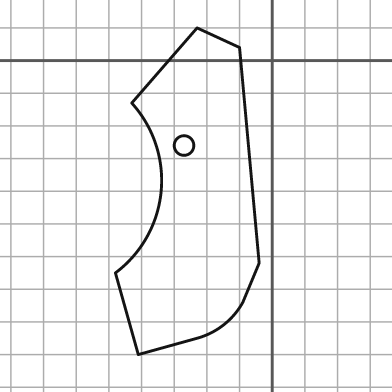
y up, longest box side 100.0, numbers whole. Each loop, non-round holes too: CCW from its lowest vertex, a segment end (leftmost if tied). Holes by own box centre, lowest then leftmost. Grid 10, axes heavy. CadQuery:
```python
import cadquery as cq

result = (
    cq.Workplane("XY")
    .moveTo(-41.0, -90.0)
    .lineTo(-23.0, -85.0)
    .threePointArc((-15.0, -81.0), (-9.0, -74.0))
    .lineTo(-4.0, -62.0)
    .lineTo(-10.0, 4.0)
    .lineTo(-23.0, 10.0)
    .lineTo(-43.0, -13.0)
    .threePointArc((-34.0, -40.0), (-48.0, -65.0))
    .close()
    .moveTo(-27.0, -26.0)
    .circle(3.0)
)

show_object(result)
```